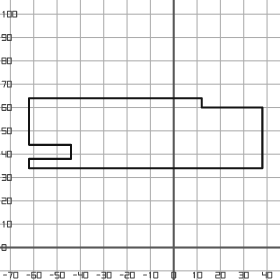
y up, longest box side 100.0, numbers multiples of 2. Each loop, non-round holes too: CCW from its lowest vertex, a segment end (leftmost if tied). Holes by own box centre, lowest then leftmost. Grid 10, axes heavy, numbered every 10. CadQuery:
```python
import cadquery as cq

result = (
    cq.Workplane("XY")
    .moveTo(-62.0, 34.0)
    .lineTo(38.0, 34.0)
    .lineTo(38.0, 60.0)
    .lineTo(12.0, 60.0)
    .lineTo(12.0, 64.0)
    .lineTo(-62.0, 64.0)
    .lineTo(-62.0, 44.0)
    .lineTo(-44.0, 44.0)
    .lineTo(-44.0, 38.0)
    .lineTo(-62.0, 38.0)
    .close()
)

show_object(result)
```